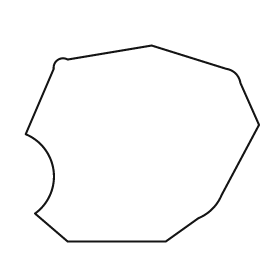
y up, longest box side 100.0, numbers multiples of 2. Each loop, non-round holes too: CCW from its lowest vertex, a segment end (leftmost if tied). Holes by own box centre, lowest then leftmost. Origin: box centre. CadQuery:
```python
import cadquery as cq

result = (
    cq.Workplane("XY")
    .moveTo(-32.0, -42.0)
    .lineTo(10.0, -42.0)
    .lineTo(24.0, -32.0)
    .threePointArc((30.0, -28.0), (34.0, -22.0))
    .lineTo(50.0, 8.0)
    .lineTo(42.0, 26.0)
    .threePointArc((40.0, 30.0), (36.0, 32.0))
    .lineTo(4.0, 42.0)
    .lineTo(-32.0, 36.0)
    .threePointArc((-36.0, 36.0), (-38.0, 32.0))
    .lineTo(-50.0, 4.0)
    .threePointArc((-38.0, -12.0), (-46.0, -30.0))
    .close()
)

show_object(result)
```